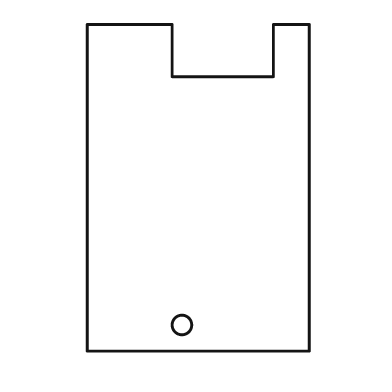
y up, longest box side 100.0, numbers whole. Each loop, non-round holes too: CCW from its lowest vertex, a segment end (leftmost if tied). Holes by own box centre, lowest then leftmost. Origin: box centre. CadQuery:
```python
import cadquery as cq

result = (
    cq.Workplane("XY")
    .moveTo(-34.0, -50.0)
    .lineTo(34.0, -50.0)
    .lineTo(34.0, 50.0)
    .lineTo(23.0, 50.0)
    .lineTo(23.0, 34.0)
    .lineTo(-8.0, 34.0)
    .lineTo(-8.0, 50.0)
    .lineTo(-34.0, 50.0)
    .close()
    .moveTo(-5.0, -42.0)
    .circle(3.0)
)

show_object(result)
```